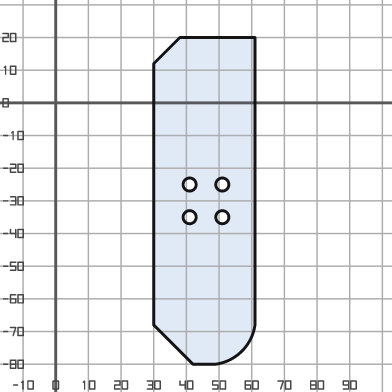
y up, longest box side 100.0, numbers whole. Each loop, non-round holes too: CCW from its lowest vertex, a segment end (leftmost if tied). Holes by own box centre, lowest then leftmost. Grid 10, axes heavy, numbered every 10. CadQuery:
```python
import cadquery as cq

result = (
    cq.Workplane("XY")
    .moveTo(42.0, -80.0)
    .lineTo(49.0, -80.0)
    .threePointArc((57.0, -76.0), (61.0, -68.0))
    .lineTo(61.0, 20.0)
    .lineTo(38.0, 20.0)
    .lineTo(30.0, 12.0)
    .lineTo(30.0, -68.0)
    .close()
    .moveTo(41.0, -35.0)
    .circle(2.0)
    .moveTo(51.0, -35.0)
    .circle(2.0)
    .moveTo(41.0, -25.0)
    .circle(2.0)
    .moveTo(51.0, -25.0)
    .circle(2.0)
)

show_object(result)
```